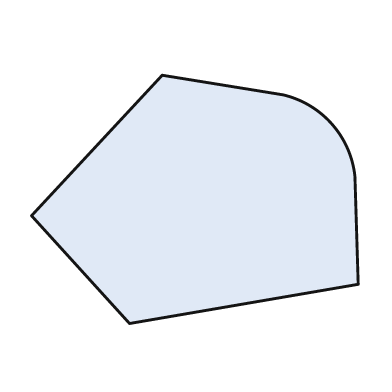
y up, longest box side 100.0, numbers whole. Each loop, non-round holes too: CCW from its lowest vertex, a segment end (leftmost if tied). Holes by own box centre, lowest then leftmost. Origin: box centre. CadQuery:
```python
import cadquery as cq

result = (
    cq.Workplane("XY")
    .moveTo(-20.0, -38.0)
    .lineTo(50.0, -26.0)
    .lineTo(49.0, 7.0)
    .threePointArc((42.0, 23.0), (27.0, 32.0))
    .lineTo(-10.0, 38.0)
    .lineTo(-50.0, -5.0)
    .close()
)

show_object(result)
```